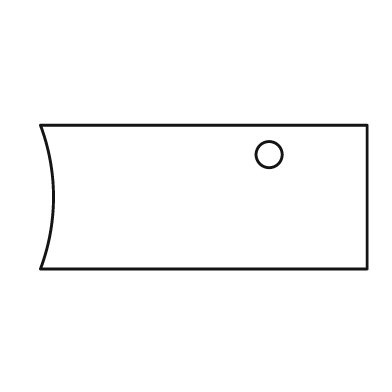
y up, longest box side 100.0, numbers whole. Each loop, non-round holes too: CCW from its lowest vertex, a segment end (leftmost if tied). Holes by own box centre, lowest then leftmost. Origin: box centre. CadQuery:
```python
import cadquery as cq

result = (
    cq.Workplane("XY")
    .moveTo(-50.0, -22.0)
    .lineTo(50.0, -22.0)
    .lineTo(50.0, 22.0)
    .lineTo(-50.0, 22.0)
    .threePointArc((-46.0, 0.0), (-50.0, -22.0))
    .close()
    .moveTo(20.0, 13.0)
    .circle(4.0)
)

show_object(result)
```